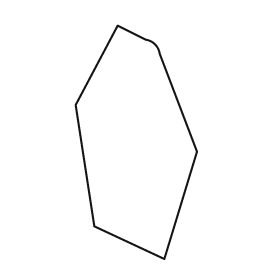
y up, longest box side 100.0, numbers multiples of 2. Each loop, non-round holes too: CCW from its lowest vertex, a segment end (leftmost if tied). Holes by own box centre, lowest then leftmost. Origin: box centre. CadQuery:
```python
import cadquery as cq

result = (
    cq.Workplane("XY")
    .moveTo(12.0, -50.0)
    .lineTo(26.0, -4.0)
    .lineTo(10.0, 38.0)
    .threePointArc((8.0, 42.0), (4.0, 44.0))
    .lineTo(-8.0, 50.0)
    .lineTo(-26.0, 16.0)
    .lineTo(-18.0, -36.0)
    .close()
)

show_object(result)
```